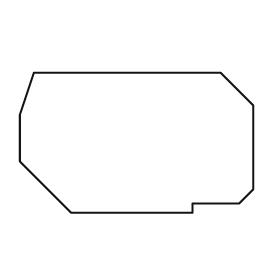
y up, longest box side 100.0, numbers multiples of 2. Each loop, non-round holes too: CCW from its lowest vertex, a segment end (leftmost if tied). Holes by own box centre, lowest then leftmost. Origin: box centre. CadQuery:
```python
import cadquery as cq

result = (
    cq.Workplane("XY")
    .moveTo(-28.0, -30.0)
    .lineTo(24.0, -30.0)
    .lineTo(24.0, -26.0)
    .lineTo(44.0, -26.0)
    .lineTo(50.0, -20.0)
    .lineTo(50.0, 16.0)
    .lineTo(36.0, 30.0)
    .lineTo(-44.0, 30.0)
    .lineTo(-50.0, 12.0)
    .lineTo(-50.0, -8.0)
    .close()
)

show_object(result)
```